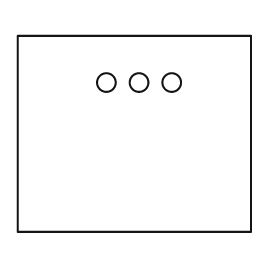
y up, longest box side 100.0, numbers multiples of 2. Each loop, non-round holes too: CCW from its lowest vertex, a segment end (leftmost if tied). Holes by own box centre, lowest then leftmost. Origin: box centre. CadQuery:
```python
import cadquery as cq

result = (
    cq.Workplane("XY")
    .moveTo(-50.0, -42.0)
    .lineTo(50.0, -42.0)
    .lineTo(50.0, 42.0)
    .lineTo(-50.0, 42.0)
    .close()
    .moveTo(-12.0, 22.0)
    .circle(4.0)
    .moveTo(2.0, 22.0)
    .circle(4.0)
    .moveTo(16.0, 22.0)
    .circle(4.0)
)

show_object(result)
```